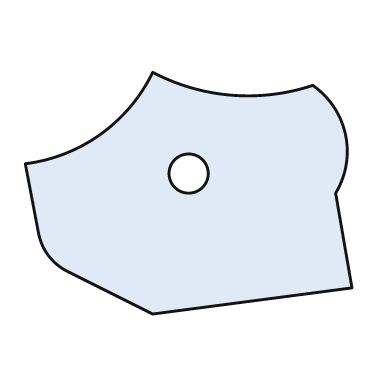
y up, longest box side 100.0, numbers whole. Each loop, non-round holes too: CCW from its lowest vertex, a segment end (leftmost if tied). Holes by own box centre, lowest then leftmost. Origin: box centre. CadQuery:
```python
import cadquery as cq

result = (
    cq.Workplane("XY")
    .moveTo(-11.0, -37.0)
    .lineTo(50.0, -29.0)
    .lineTo(45.0, 0.0)
    .threePointArc((48.0, 18.0), (38.0, 33.0))
    .threePointArc((13.0, 30.0), (-11.0, 37.0))
    .threePointArc((-27.0, 18.0), (-50.0, 9.0))
    .lineTo(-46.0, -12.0)
    .threePointArc((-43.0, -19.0), (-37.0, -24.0))
    .close()
    .moveTo(0.0, 6.0)
    .circle(6.0)
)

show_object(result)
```